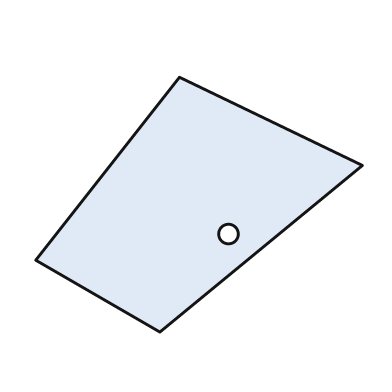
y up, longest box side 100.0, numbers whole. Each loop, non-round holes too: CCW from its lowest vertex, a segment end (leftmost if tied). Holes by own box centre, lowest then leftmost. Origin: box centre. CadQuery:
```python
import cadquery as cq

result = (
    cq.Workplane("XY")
    .moveTo(-12.0, -39.0)
    .lineTo(50.0, 12.0)
    .lineTo(-6.0, 39.0)
    .lineTo(-50.0, -17.0)
    .close()
    .moveTo(9.0, -9.0)
    .circle(3.0)
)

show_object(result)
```